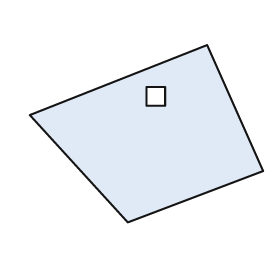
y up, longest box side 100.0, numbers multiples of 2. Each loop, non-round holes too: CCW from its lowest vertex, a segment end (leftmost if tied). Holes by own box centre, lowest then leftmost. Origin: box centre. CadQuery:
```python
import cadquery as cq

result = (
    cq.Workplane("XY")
    .moveTo(-8.0, -38.0)
    .lineTo(50.0, -16.0)
    .lineTo(26.0, 38.0)
    .lineTo(-50.0, 8.0)
    .close()
    .moveTo(0.0, 12.0)
    .lineTo(8.0, 12.0)
    .lineTo(8.0, 20.0)
    .lineTo(0.0, 20.0)
    .close()
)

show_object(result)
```